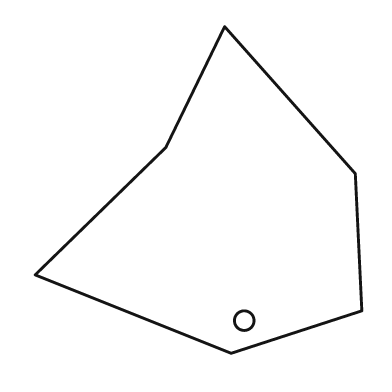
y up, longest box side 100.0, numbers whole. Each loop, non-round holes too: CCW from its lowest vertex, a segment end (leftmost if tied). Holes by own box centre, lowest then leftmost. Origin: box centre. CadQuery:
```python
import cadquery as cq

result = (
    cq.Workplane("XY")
    .moveTo(10.0, -50.0)
    .lineTo(50.0, -37.0)
    .lineTo(48.0, 5.0)
    .lineTo(8.0, 50.0)
    .lineTo(-10.0, 13.0)
    .lineTo(-50.0, -26.0)
    .close()
    .moveTo(14.0, -40.0)
    .circle(3.0)
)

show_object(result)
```